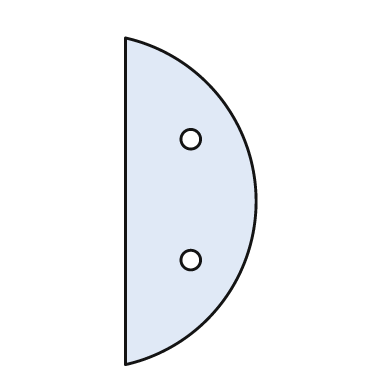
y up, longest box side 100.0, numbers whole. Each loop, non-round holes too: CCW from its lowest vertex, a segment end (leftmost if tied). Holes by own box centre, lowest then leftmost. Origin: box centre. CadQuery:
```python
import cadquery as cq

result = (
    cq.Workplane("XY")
    .moveTo(-20.0, -50.0)
    .threePointArc((20.0, 0.0), (-20.0, 50.0))
    .close()
    .moveTo(0.0, -18.0)
    .circle(3.0)
    .moveTo(0.0, 19.0)
    .circle(3.0)
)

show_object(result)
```